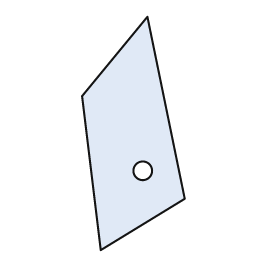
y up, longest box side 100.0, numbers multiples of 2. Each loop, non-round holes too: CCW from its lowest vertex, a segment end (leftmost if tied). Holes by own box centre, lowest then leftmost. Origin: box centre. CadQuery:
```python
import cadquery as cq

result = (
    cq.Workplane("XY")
    .moveTo(-14.0, -50.0)
    .lineTo(22.0, -28.0)
    .lineTo(6.0, 50.0)
    .lineTo(-22.0, 16.0)
    .close()
    .moveTo(4.0, -16.0)
    .circle(4.0)
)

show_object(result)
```